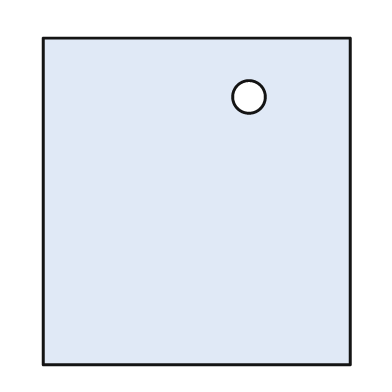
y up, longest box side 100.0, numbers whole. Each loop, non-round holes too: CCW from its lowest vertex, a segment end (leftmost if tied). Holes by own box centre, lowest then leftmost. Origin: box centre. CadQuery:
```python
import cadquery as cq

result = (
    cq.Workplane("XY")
    .moveTo(-47.0, -50.0)
    .lineTo(47.0, -50.0)
    .lineTo(47.0, 50.0)
    .lineTo(-47.0, 50.0)
    .close()
    .moveTo(16.0, 32.0)
    .circle(5.0)
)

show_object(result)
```